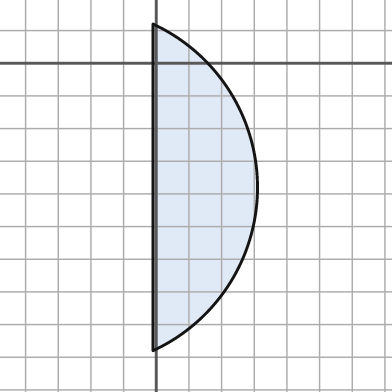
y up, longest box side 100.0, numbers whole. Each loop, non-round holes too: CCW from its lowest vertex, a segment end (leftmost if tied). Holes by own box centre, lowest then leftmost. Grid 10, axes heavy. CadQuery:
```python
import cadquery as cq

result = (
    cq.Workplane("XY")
    .moveTo(-1.0, -88.0)
    .threePointArc((31.0, -38.0), (-1.0, 12.0))
    .close()
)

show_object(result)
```